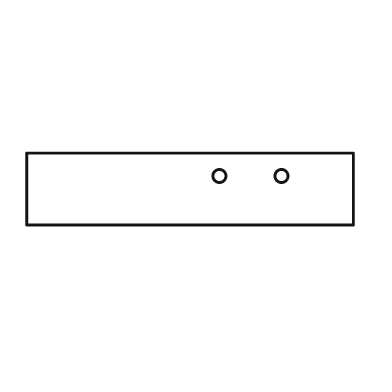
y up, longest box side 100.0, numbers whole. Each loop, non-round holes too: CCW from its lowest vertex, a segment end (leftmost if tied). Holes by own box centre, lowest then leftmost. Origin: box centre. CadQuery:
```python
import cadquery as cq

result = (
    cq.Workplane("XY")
    .moveTo(-50.0, -11.0)
    .lineTo(50.0, -11.0)
    .lineTo(50.0, 11.0)
    .lineTo(-50.0, 11.0)
    .close()
    .moveTo(9.0, 4.0)
    .circle(2.0)
    .moveTo(28.0, 4.0)
    .circle(2.0)
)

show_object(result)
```